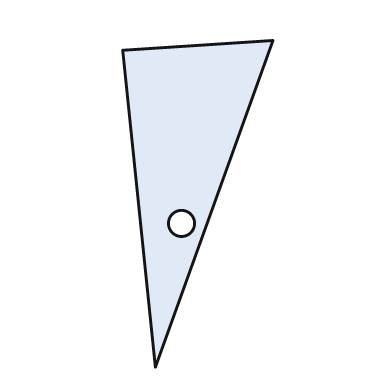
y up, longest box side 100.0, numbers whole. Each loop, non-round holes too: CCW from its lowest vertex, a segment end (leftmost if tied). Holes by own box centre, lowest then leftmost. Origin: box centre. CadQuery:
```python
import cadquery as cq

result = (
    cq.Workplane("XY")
    .moveTo(-13.0, -50.0)
    .lineTo(23.0, 50.0)
    .lineTo(-23.0, 47.0)
    .close()
    .moveTo(-5.0, -6.0)
    .circle(4.0)
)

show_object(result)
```